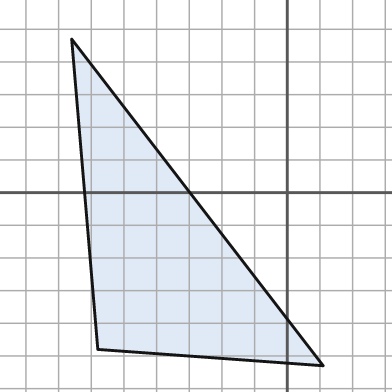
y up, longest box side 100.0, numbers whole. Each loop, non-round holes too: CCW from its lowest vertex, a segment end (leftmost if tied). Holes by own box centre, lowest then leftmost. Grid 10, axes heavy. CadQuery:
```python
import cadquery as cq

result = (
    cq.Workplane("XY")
    .moveTo(11.0, -53.0)
    .lineTo(-66.0, 47.0)
    .lineTo(-58.0, -48.0)
    .close()
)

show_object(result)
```